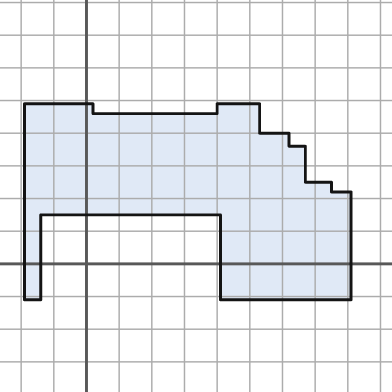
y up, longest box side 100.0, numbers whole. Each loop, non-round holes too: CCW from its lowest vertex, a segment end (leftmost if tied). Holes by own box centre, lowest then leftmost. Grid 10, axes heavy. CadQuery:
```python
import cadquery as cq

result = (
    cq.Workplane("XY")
    .moveTo(-19.0, -11.0)
    .lineTo(-14.0, -11.0)
    .lineTo(-14.0, 15.0)
    .lineTo(41.0, 15.0)
    .lineTo(41.0, -11.0)
    .lineTo(81.0, -11.0)
    .lineTo(81.0, 22.0)
    .lineTo(75.0, 22.0)
    .lineTo(75.0, 25.0)
    .lineTo(67.0, 25.0)
    .lineTo(67.0, 36.0)
    .lineTo(62.0, 36.0)
    .lineTo(62.0, 40.0)
    .lineTo(53.0, 40.0)
    .lineTo(53.0, 49.0)
    .lineTo(40.0, 49.0)
    .lineTo(40.0, 46.0)
    .lineTo(2.0, 46.0)
    .lineTo(2.0, 49.0)
    .lineTo(-19.0, 49.0)
    .close()
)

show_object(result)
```